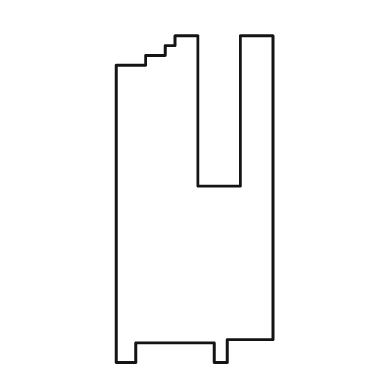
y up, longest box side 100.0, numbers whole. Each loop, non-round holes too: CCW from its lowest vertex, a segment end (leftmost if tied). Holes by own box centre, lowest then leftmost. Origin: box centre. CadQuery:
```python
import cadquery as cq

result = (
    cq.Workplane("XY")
    .moveTo(-24.0, -50.0)
    .lineTo(-18.0, -50.0)
    .lineTo(-18.0, -44.0)
    .lineTo(6.0, -44.0)
    .lineTo(6.0, -50.0)
    .lineTo(10.0, -50.0)
    .lineTo(10.0, -43.0)
    .lineTo(24.0, -43.0)
    .lineTo(24.0, 50.0)
    .lineTo(14.0, 50.0)
    .lineTo(14.0, 4.0)
    .lineTo(1.0, 4.0)
    .lineTo(1.0, 50.0)
    .lineTo(-6.0, 50.0)
    .lineTo(-6.0, 47.0)
    .lineTo(-9.0, 47.0)
    .lineTo(-9.0, 44.0)
    .lineTo(-15.0, 44.0)
    .lineTo(-15.0, 41.0)
    .lineTo(-24.0, 41.0)
    .close()
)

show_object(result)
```